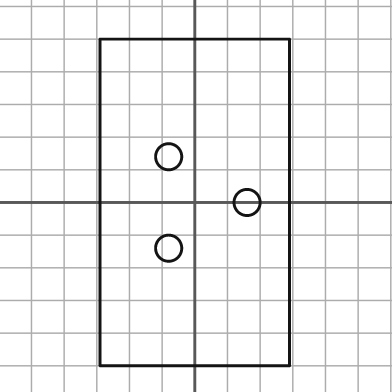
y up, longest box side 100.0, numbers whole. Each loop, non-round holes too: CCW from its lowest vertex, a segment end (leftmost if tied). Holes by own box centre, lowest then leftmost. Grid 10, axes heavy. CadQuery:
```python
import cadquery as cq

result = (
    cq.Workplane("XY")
    .moveTo(-29.0, -50.0)
    .lineTo(29.0, -50.0)
    .lineTo(29.0, 50.0)
    .lineTo(-29.0, 50.0)
    .close()
    .moveTo(-8.0, -14.0)
    .circle(4.0)
    .moveTo(16.0, 0.0)
    .circle(4.0)
    .moveTo(-8.0, 14.0)
    .circle(4.0)
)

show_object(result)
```